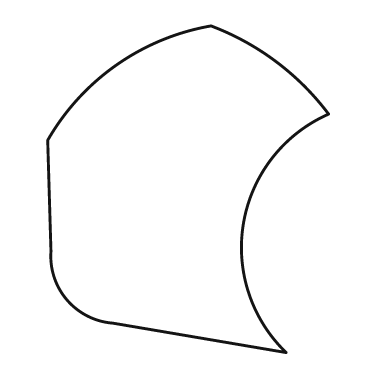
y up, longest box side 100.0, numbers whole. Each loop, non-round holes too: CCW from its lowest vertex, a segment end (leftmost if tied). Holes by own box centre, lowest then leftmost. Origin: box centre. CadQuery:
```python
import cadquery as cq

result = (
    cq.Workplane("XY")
    .moveTo(30.0, -50.0)
    .threePointArc((17.0, -10.0), (43.0, 23.0))
    .threePointArc((27.0, 39.0), (7.0, 50.0))
    .threePointArc((-22.0, 38.0), (-43.0, 15.0))
    .lineTo(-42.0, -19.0)
    .threePointArc((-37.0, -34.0), (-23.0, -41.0))
    .close()
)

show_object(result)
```